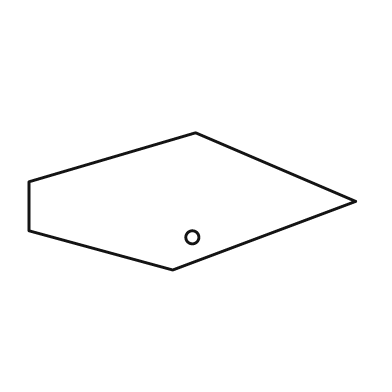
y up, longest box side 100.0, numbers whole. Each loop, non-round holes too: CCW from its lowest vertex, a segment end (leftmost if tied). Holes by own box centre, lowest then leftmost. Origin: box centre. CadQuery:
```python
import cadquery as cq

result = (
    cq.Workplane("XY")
    .moveTo(-6.0, -21.0)
    .lineTo(50.0, 0.0)
    .lineTo(1.0, 21.0)
    .lineTo(-50.0, 6.0)
    .lineTo(-50.0, -9.0)
    .close()
    .moveTo(0.0, -11.0)
    .circle(2.0)
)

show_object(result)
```